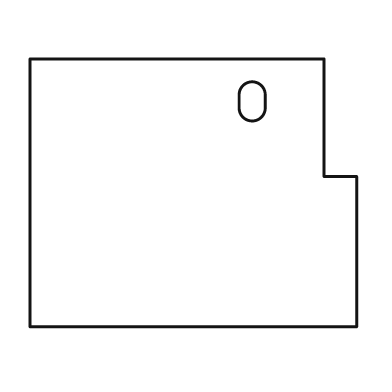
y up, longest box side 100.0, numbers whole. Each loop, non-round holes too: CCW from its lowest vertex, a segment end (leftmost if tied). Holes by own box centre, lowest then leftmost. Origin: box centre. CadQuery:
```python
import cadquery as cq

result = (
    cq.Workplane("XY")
    .moveTo(-50.0, -41.0)
    .lineTo(50.0, -41.0)
    .lineTo(50.0, 5.0)
    .lineTo(40.0, 5.0)
    .lineTo(40.0, 41.0)
    .lineTo(-50.0, 41.0)
    .close()
    .moveTo(14.0, 26.0)
    .threePointArc((18.0, 22.0), (22.0, 26.0))
    .lineTo(22.0, 30.0)
    .threePointArc((18.0, 34.0), (14.0, 30.0))
    .close()
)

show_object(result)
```